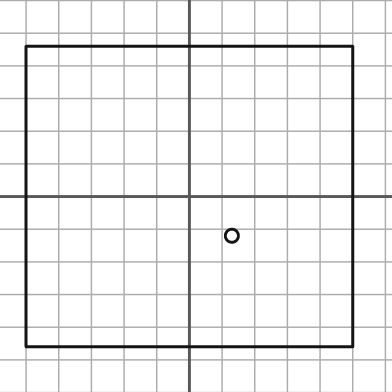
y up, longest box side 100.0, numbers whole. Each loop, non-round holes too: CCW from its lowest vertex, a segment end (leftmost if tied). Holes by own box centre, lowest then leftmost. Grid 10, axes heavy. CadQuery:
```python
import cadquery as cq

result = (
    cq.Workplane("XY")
    .moveTo(-50.0, -46.0)
    .lineTo(50.0, -46.0)
    .lineTo(50.0, 46.0)
    .lineTo(-50.0, 46.0)
    .close()
    .moveTo(13.0, -12.0)
    .circle(2.0)
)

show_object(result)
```